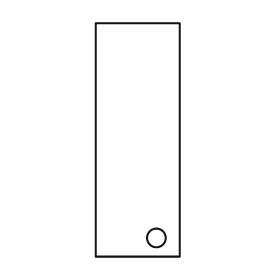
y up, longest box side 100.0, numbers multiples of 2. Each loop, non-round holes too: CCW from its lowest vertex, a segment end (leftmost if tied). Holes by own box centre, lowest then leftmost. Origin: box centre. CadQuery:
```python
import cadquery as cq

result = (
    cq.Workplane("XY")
    .moveTo(-18.0, -50.0)
    .lineTo(18.0, -50.0)
    .lineTo(18.0, 50.0)
    .lineTo(-18.0, 50.0)
    .close()
    .moveTo(8.0, -42.0)
    .circle(4.0)
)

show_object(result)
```